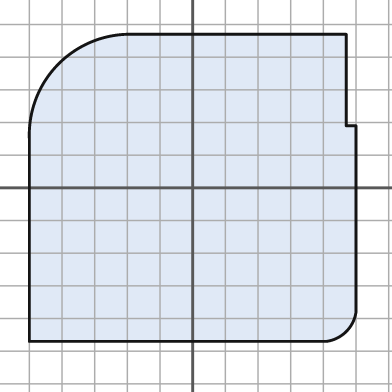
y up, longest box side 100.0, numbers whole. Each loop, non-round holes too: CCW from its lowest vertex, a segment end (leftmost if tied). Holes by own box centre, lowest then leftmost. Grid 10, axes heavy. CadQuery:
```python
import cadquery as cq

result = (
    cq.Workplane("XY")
    .moveTo(-50.0, -47.0)
    .lineTo(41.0, -47.0)
    .threePointArc((47.0, -44.0), (50.0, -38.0))
    .lineTo(50.0, 19.0)
    .lineTo(47.0, 19.0)
    .lineTo(47.0, 47.0)
    .lineTo(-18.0, 47.0)
    .threePointArc((-41.0, 38.0), (-50.0, 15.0))
    .close()
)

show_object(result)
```